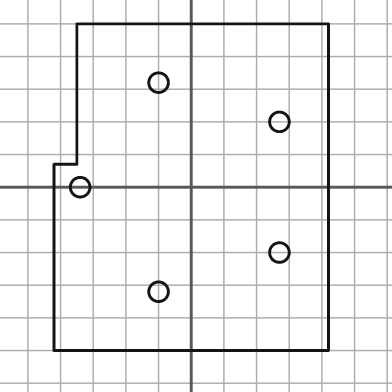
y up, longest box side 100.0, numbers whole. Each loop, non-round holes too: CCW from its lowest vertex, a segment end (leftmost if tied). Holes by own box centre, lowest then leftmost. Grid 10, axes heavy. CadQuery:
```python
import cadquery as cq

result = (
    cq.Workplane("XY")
    .moveTo(-42.0, -50.0)
    .lineTo(42.0, -50.0)
    .lineTo(42.0, 50.0)
    .lineTo(-35.0, 50.0)
    .lineTo(-35.0, 7.0)
    .lineTo(-42.0, 7.0)
    .close()
    .moveTo(-10.0, -32.0)
    .circle(3.0)
    .moveTo(27.0, -20.0)
    .circle(3.0)
    .moveTo(-34.0, 0.0)
    .circle(3.0)
    .moveTo(27.0, 20.0)
    .circle(3.0)
    .moveTo(-10.0, 32.0)
    .circle(3.0)
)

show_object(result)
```